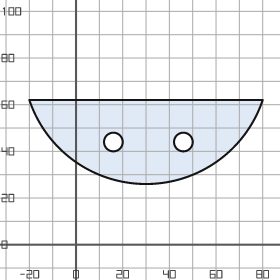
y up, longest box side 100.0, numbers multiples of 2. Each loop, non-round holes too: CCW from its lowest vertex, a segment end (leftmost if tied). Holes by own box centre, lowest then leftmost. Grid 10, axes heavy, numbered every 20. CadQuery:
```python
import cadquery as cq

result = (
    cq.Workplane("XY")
    .moveTo(-20.0, 62.0)
    .threePointArc((30.0, 26.0), (80.0, 62.0))
    .close()
    .moveTo(16.0, 44.0)
    .circle(4.0)
    .moveTo(46.0, 44.0)
    .circle(4.0)
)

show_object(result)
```